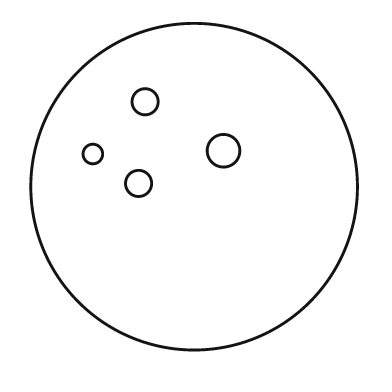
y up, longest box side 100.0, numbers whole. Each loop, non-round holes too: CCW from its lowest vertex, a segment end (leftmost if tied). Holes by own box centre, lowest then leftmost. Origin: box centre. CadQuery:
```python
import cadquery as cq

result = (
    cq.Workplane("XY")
    .moveTo(0.0, 0.0)
    .circle(50.0)
    .moveTo(-17.0, 1.0)
    .circle(4.0)
    .moveTo(-31.0, 10.0)
    .circle(3.0)
    .moveTo(9.0, 11.0)
    .circle(5.0)
    .moveTo(-15.0, 26.0)
    .circle(4.0)
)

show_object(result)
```